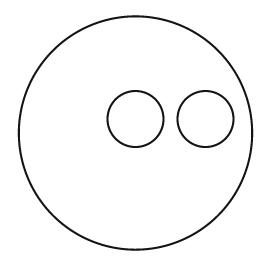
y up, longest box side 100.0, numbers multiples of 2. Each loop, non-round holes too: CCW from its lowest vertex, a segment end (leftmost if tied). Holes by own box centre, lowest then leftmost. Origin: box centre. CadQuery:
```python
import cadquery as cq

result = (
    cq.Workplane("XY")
    .moveTo(0.0, 0.0)
    .circle(50.0)
    .moveTo(0.0, 6.0)
    .circle(12.0)
    .moveTo(30.0, 6.0)
    .circle(12.0)
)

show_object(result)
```